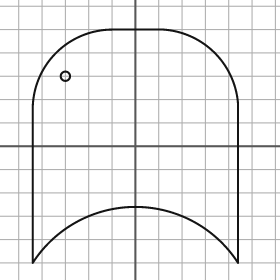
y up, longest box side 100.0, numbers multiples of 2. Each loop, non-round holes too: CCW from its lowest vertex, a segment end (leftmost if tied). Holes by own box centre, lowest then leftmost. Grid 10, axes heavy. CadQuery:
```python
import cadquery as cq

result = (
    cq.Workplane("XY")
    .moveTo(-44.0, -50.0)
    .threePointArc((0.0, -26.0), (44.0, -50.0))
    .lineTo(44.0, 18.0)
    .threePointArc((34.0, 40.0), (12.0, 50.0))
    .lineTo(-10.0, 50.0)
    .threePointArc((-34.0, 40.0), (-44.0, 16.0))
    .close()
    .moveTo(-30.0, 30.0)
    .circle(2.0)
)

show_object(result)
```